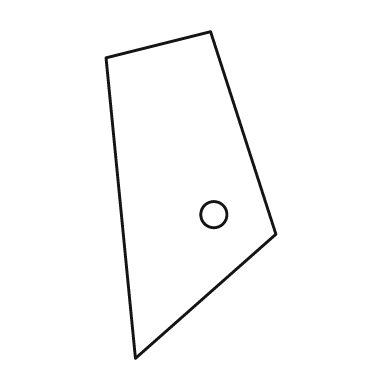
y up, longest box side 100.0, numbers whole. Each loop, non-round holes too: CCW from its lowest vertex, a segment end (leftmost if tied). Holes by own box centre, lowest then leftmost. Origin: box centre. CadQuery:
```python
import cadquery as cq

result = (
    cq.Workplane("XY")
    .moveTo(-17.0, -50.0)
    .lineTo(26.0, -12.0)
    .lineTo(6.0, 50.0)
    .lineTo(-26.0, 42.0)
    .close()
    .moveTo(7.0, -6.0)
    .circle(4.0)
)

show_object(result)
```